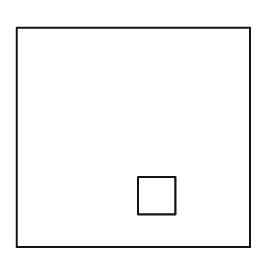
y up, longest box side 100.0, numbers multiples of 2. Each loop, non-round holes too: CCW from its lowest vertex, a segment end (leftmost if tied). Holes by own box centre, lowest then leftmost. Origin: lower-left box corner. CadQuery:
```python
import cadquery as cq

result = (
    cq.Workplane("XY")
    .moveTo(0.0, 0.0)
    .lineTo(100.0, 0.0)
    .lineTo(100.0, 94.0)
    .lineTo(0.0, 94.0)
    .close()
    .moveTo(52.0, 14.0)
    .lineTo(68.0, 14.0)
    .lineTo(68.0, 30.0)
    .lineTo(52.0, 30.0)
    .close()
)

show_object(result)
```